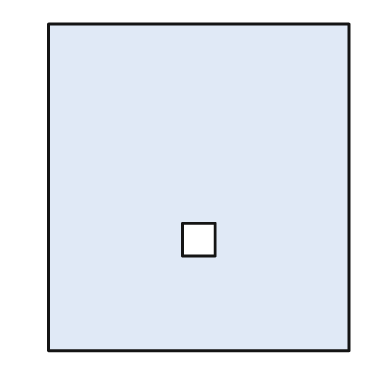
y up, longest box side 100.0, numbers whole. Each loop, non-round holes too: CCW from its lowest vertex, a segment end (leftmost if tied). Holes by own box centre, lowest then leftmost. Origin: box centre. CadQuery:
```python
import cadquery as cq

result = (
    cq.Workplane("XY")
    .moveTo(-46.0, -50.0)
    .lineTo(46.0, -50.0)
    .lineTo(46.0, 50.0)
    .lineTo(-46.0, 50.0)
    .close()
    .moveTo(-5.0, -21.0)
    .lineTo(5.0, -21.0)
    .lineTo(5.0, -11.0)
    .lineTo(-5.0, -11.0)
    .close()
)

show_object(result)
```